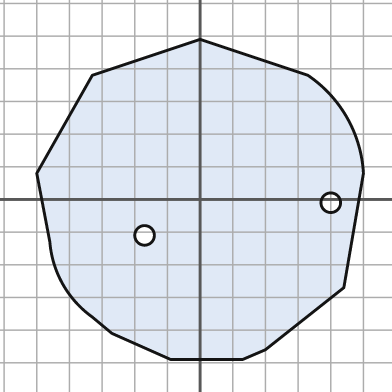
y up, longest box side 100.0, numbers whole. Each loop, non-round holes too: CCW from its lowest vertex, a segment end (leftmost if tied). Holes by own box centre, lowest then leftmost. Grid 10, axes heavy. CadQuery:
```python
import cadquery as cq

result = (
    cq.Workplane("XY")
    .moveTo(-9.0, -49.0)
    .lineTo(13.0, -49.0)
    .lineTo(20.0, -46.0)
    .lineTo(44.0, -27.0)
    .lineTo(50.0, 8.0)
    .threePointArc((45.0, 25.0), (33.0, 38.0))
    .lineTo(0.0, 49.0)
    .lineTo(-33.0, 38.0)
    .lineTo(-50.0, 8.0)
    .lineTo(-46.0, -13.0)
    .threePointArc((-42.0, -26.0), (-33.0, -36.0))
    .lineTo(-27.0, -41.0)
    .close()
    .moveTo(-17.0, -11.0)
    .circle(3.0)
    .moveTo(40.0, -1.0)
    .circle(3.0)
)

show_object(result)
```